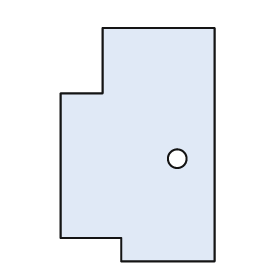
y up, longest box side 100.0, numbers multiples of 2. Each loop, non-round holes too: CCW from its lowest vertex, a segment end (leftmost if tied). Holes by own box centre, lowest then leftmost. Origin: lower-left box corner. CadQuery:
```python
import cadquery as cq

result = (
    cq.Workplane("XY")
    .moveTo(26.0, 0.0)
    .lineTo(66.0, 0.0)
    .lineTo(66.0, 100.0)
    .lineTo(18.0, 100.0)
    .lineTo(18.0, 72.0)
    .lineTo(0.0, 72.0)
    .lineTo(0.0, 10.0)
    .lineTo(26.0, 10.0)
    .close()
    .moveTo(50.0, 44.0)
    .circle(4.0)
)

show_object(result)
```